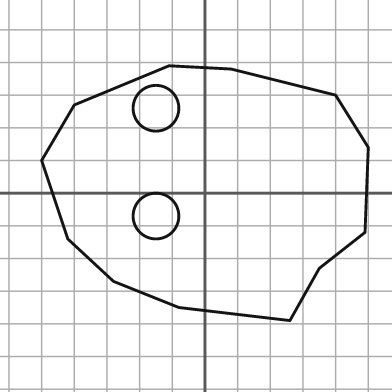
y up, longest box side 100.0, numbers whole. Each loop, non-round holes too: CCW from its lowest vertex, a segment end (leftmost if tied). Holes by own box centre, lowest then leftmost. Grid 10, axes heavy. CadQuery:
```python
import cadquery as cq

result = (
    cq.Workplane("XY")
    .moveTo(26.0, -39.0)
    .lineTo(35.0, -23.0)
    .lineTo(49.0, -12.0)
    .lineTo(50.0, 14.0)
    .lineTo(40.0, 30.0)
    .lineTo(8.0, 38.0)
    .lineTo(-11.0, 39.0)
    .lineTo(-40.0, 27.0)
    .lineTo(-50.0, 10.0)
    .lineTo(-42.0, -14.0)
    .lineTo(-28.0, -27.0)
    .lineTo(-8.0, -35.0)
    .close()
    .moveTo(-15.0, -7.0)
    .circle(7.0)
    .moveTo(-15.0, 26.0)
    .circle(7.0)
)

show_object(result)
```